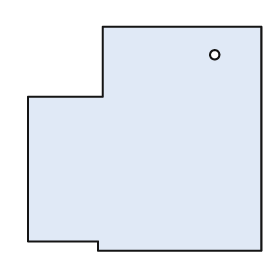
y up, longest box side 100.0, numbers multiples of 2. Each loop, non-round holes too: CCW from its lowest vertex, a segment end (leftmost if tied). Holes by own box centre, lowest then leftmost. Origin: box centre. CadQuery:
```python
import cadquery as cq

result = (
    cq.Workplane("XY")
    .moveTo(-20.0, -48.0)
    .lineTo(50.0, -48.0)
    .lineTo(50.0, 48.0)
    .lineTo(-18.0, 48.0)
    .lineTo(-18.0, 18.0)
    .lineTo(-50.0, 18.0)
    .lineTo(-50.0, -44.0)
    .lineTo(-20.0, -44.0)
    .close()
    .moveTo(30.0, 36.0)
    .circle(2.0)
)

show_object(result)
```